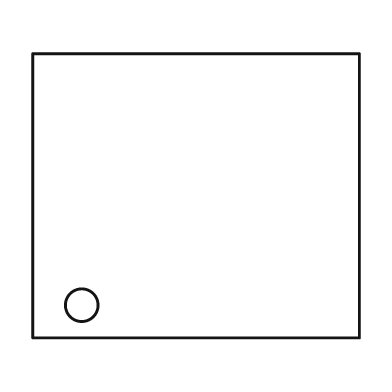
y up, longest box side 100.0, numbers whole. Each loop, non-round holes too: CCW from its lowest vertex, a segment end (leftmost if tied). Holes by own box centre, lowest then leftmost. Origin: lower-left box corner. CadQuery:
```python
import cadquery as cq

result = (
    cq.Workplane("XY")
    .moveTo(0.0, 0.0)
    .lineTo(100.0, 0.0)
    .lineTo(100.0, 87.0)
    .lineTo(0.0, 87.0)
    .close()
    .moveTo(15.0, 10.0)
    .circle(5.0)
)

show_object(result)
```